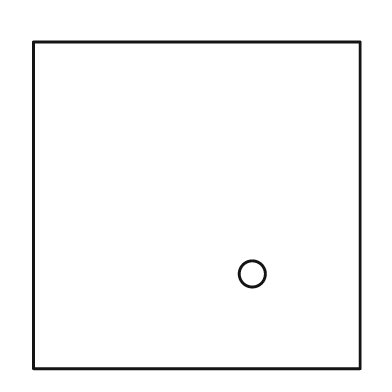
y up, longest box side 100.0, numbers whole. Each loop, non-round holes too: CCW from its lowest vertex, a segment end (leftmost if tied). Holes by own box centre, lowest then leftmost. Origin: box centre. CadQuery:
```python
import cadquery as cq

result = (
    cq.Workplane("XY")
    .moveTo(-50.0, -50.0)
    .lineTo(50.0, -50.0)
    .lineTo(50.0, 50.0)
    .lineTo(-50.0, 50.0)
    .close()
    .moveTo(17.0, -21.0)
    .circle(4.0)
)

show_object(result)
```